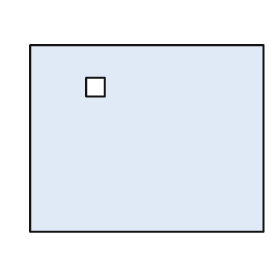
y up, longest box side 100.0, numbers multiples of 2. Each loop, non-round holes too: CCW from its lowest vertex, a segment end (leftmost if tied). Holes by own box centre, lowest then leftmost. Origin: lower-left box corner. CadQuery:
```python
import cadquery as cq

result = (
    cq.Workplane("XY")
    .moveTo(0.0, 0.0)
    .lineTo(100.0, 0.0)
    .lineTo(100.0, 80.0)
    .lineTo(0.0, 80.0)
    .close()
    .moveTo(24.0, 58.0)
    .lineTo(32.0, 58.0)
    .lineTo(32.0, 66.0)
    .lineTo(24.0, 66.0)
    .close()
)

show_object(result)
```